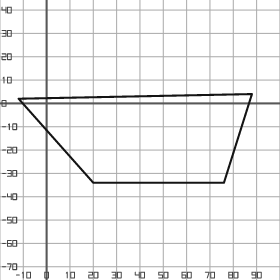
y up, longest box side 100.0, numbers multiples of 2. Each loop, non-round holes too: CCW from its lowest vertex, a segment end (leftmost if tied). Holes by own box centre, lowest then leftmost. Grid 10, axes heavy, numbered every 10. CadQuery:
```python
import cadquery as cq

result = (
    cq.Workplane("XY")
    .moveTo(20.0, -34.0)
    .lineTo(76.0, -34.0)
    .lineTo(88.0, 4.0)
    .lineTo(-12.0, 2.0)
    .close()
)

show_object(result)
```